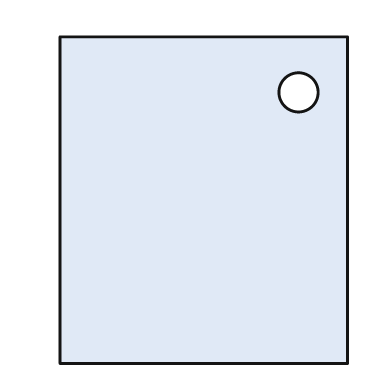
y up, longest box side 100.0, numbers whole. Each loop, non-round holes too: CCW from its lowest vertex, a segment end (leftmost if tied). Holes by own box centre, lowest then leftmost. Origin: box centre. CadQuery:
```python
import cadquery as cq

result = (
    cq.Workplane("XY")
    .moveTo(-44.0, -50.0)
    .lineTo(44.0, -50.0)
    .lineTo(44.0, 50.0)
    .lineTo(-44.0, 50.0)
    .close()
    .moveTo(29.0, 33.0)
    .circle(6.0)
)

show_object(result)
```